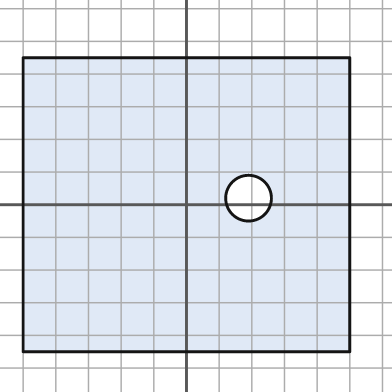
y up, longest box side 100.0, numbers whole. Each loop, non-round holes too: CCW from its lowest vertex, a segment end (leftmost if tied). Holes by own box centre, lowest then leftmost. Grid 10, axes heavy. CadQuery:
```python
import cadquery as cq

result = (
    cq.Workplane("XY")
    .moveTo(-50.0, -45.0)
    .lineTo(50.0, -45.0)
    .lineTo(50.0, 45.0)
    .lineTo(-50.0, 45.0)
    .close()
    .moveTo(19.0, 2.0)
    .circle(7.0)
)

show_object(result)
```